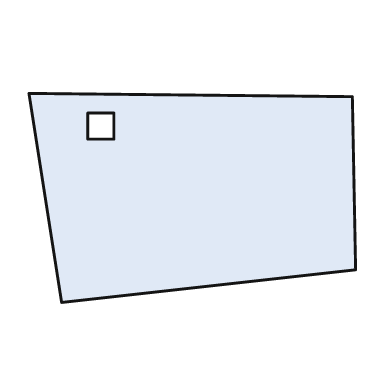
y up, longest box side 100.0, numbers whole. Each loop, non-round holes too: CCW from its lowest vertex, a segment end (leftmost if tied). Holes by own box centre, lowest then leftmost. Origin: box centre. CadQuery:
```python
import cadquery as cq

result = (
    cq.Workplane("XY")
    .moveTo(-40.0, -32.0)
    .lineTo(50.0, -22.0)
    .lineTo(49.0, 31.0)
    .lineTo(-50.0, 32.0)
    .close()
    .moveTo(-32.0, 18.0)
    .lineTo(-24.0, 18.0)
    .lineTo(-24.0, 26.0)
    .lineTo(-32.0, 26.0)
    .close()
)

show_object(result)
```